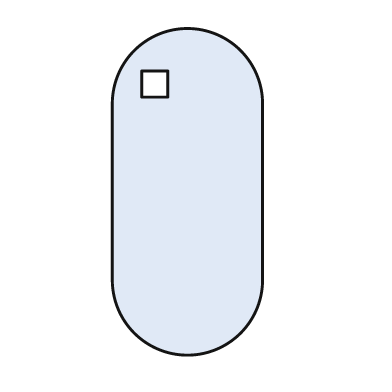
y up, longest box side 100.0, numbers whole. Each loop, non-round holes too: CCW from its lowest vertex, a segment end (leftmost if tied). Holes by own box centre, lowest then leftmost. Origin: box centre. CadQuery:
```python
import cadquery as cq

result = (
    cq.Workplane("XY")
    .moveTo(-23.0, -27.0)
    .threePointArc((0.0, -50.0), (23.0, -27.0))
    .lineTo(23.0, 27.0)
    .threePointArc((0.0, 50.0), (-23.0, 27.0))
    .close()
    .moveTo(-14.0, 29.0)
    .lineTo(-6.0, 29.0)
    .lineTo(-6.0, 37.0)
    .lineTo(-14.0, 37.0)
    .close()
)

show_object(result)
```